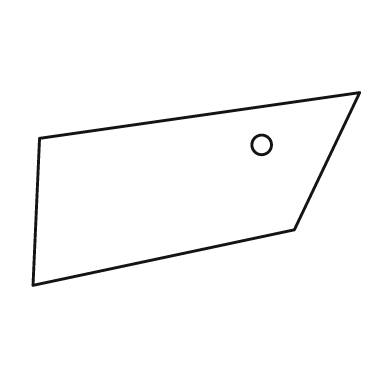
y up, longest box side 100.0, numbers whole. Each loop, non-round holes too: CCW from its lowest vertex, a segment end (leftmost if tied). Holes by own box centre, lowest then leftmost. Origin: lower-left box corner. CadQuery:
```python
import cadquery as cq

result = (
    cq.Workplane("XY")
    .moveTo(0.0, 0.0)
    .lineTo(80.0, 17.0)
    .lineTo(100.0, 59.0)
    .lineTo(2.0, 45.0)
    .close()
    .moveTo(70.0, 43.0)
    .circle(3.0)
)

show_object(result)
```